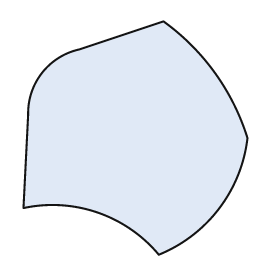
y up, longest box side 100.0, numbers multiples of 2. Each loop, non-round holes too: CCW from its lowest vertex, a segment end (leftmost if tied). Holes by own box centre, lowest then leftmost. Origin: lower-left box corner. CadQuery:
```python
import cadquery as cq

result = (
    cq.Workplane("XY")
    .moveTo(58.0, 0.0)
    .threePointArc((84.0, 20.0), (96.0, 50.0))
    .threePointArc((82.0, 78.0), (60.0, 100.0))
    .lineTo(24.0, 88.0)
    .threePointArc((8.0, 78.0), (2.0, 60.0))
    .lineTo(0.0, 20.0)
    .threePointArc((32.0, 18.0), (58.0, 0.0))
    .close()
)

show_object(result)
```